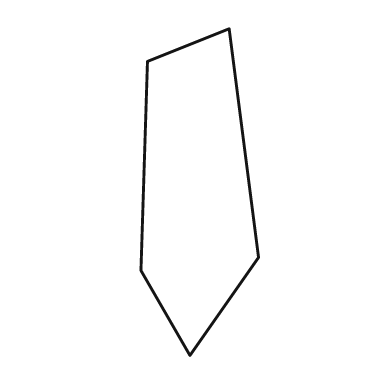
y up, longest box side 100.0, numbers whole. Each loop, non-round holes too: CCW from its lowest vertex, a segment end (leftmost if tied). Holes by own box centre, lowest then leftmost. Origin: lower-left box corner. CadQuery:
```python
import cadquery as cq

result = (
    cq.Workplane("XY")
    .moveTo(15.0, 0.0)
    .lineTo(36.0, 30.0)
    .lineTo(27.0, 100.0)
    .lineTo(2.0, 90.0)
    .lineTo(0.0, 26.0)
    .close()
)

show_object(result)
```